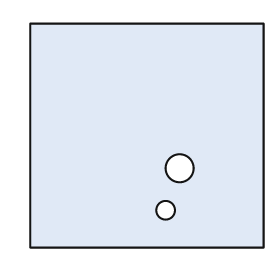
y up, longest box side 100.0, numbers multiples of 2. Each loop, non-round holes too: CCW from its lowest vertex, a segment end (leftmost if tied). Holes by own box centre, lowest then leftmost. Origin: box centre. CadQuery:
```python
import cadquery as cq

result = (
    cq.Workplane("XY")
    .moveTo(-50.0, -48.0)
    .lineTo(50.0, -48.0)
    .lineTo(50.0, 48.0)
    .lineTo(-50.0, 48.0)
    .close()
    .moveTo(8.0, -32.0)
    .circle(4.0)
    .moveTo(14.0, -14.0)
    .circle(6.0)
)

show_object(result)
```